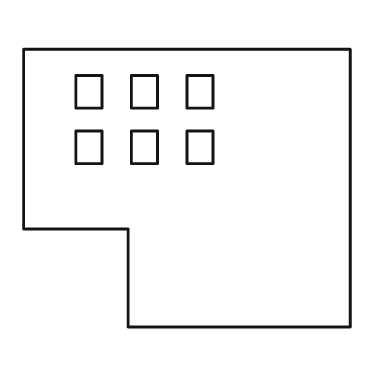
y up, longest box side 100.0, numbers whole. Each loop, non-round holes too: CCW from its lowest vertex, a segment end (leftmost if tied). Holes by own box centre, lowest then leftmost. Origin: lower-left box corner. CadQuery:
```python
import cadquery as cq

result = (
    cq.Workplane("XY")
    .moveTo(32.0, 0.0)
    .lineTo(100.0, 0.0)
    .lineTo(100.0, 85.0)
    .lineTo(0.0, 85.0)
    .lineTo(0.0, 30.0)
    .lineTo(32.0, 30.0)
    .close()
    .moveTo(16.0, 50.0)
    .lineTo(24.0, 50.0)
    .lineTo(24.0, 60.0)
    .lineTo(16.0, 60.0)
    .close()
    .moveTo(33.0, 50.0)
    .lineTo(41.0, 50.0)
    .lineTo(41.0, 60.0)
    .lineTo(33.0, 60.0)
    .close()
    .moveTo(50.0, 50.0)
    .lineTo(58.0, 50.0)
    .lineTo(58.0, 60.0)
    .lineTo(50.0, 60.0)
    .close()
    .moveTo(16.0, 67.0)
    .lineTo(24.0, 67.0)
    .lineTo(24.0, 77.0)
    .lineTo(16.0, 77.0)
    .close()
    .moveTo(33.0, 67.0)
    .lineTo(41.0, 67.0)
    .lineTo(41.0, 77.0)
    .lineTo(33.0, 77.0)
    .close()
    .moveTo(50.0, 67.0)
    .lineTo(58.0, 67.0)
    .lineTo(58.0, 77.0)
    .lineTo(50.0, 77.0)
    .close()
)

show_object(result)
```